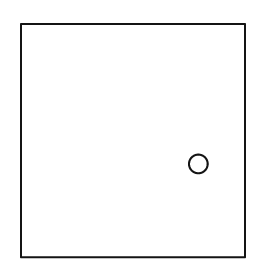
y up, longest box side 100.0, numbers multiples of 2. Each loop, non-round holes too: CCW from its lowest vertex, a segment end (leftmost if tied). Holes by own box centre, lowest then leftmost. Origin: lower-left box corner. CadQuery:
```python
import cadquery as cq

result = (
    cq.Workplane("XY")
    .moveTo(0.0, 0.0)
    .lineTo(96.0, 0.0)
    .lineTo(96.0, 100.0)
    .lineTo(0.0, 100.0)
    .close()
    .moveTo(76.0, 40.0)
    .circle(4.0)
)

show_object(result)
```